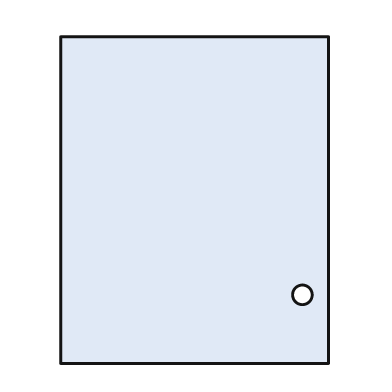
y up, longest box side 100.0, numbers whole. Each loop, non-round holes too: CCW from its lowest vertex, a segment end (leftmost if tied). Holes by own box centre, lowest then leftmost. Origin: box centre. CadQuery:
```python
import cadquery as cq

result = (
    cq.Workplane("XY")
    .moveTo(-41.0, -50.0)
    .lineTo(41.0, -50.0)
    .lineTo(41.0, 50.0)
    .lineTo(-41.0, 50.0)
    .close()
    .moveTo(33.0, -29.0)
    .circle(3.0)
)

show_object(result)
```